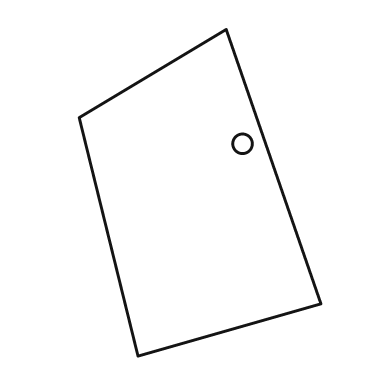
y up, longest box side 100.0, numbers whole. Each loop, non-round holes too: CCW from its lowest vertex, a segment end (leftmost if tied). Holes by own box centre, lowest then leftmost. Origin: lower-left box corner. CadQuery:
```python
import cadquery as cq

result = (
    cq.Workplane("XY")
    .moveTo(18.0, 0.0)
    .lineTo(74.0, 16.0)
    .lineTo(45.0, 100.0)
    .lineTo(0.0, 73.0)
    .close()
    .moveTo(50.0, 65.0)
    .circle(3.0)
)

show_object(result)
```